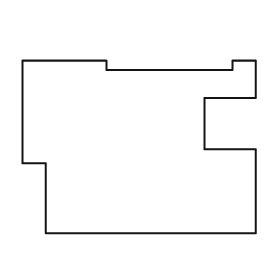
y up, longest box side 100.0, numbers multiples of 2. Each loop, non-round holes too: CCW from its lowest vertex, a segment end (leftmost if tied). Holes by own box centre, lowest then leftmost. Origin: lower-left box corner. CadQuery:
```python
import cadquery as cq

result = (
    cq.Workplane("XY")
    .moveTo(10.0, 0.0)
    .lineTo(100.0, 0.0)
    .lineTo(100.0, 36.0)
    .lineTo(78.0, 36.0)
    .lineTo(78.0, 58.0)
    .lineTo(100.0, 58.0)
    .lineTo(100.0, 74.0)
    .lineTo(90.0, 74.0)
    .lineTo(90.0, 70.0)
    .lineTo(36.0, 70.0)
    .lineTo(36.0, 74.0)
    .lineTo(0.0, 74.0)
    .lineTo(0.0, 30.0)
    .lineTo(10.0, 30.0)
    .close()
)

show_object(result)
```